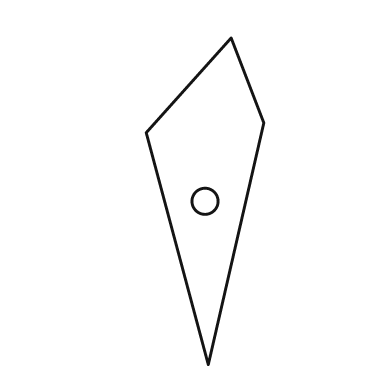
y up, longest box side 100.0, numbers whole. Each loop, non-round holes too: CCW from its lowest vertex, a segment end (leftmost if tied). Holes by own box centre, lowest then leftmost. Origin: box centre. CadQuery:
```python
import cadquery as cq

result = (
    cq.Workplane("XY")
    .moveTo(1.0, -50.0)
    .lineTo(18.0, 24.0)
    .lineTo(8.0, 50.0)
    .lineTo(-18.0, 21.0)
    .close()
    .moveTo(0.0, 0.0)
    .circle(4.0)
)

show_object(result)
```